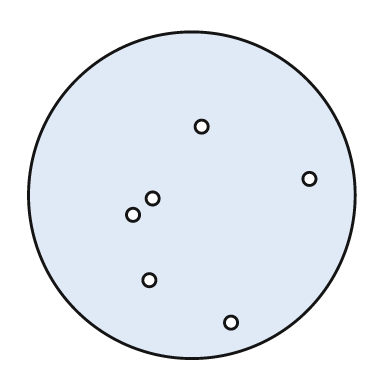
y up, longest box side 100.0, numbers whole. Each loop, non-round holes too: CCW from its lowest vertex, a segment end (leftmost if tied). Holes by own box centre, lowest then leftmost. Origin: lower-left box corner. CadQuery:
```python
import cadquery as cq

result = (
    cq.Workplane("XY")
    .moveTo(50.0, 50.0)
    .circle(50.0)
    .moveTo(62.0, 11.0)
    .circle(2.0)
    .moveTo(37.0, 24.0)
    .circle(2.0)
    .moveTo(32.0, 44.0)
    .circle(2.0)
    .moveTo(38.0, 49.0)
    .circle(2.0)
    .moveTo(86.0, 55.0)
    .circle(2.0)
    .moveTo(53.0, 71.0)
    .circle(2.0)
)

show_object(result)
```